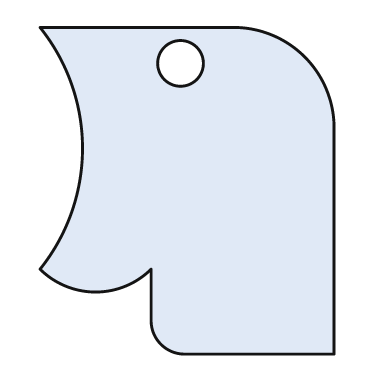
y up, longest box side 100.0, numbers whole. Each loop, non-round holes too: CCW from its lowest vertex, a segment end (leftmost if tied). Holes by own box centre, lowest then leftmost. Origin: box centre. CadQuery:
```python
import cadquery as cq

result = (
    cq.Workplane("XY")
    .moveTo(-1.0, -50.0)
    .lineTo(45.0, -50.0)
    .lineTo(45.0, 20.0)
    .threePointArc((36.0, 41.0), (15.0, 50.0))
    .lineTo(-45.0, 50.0)
    .threePointArc((-32.0, 13.0), (-45.0, -24.0))
    .threePointArc((-28.0, -31.0), (-11.0, -24.0))
    .lineTo(-11.0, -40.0)
    .threePointArc((-8.0, -47.0), (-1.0, -50.0))
    .close()
    .moveTo(-2.0, 39.0)
    .circle(7.0)
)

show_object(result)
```